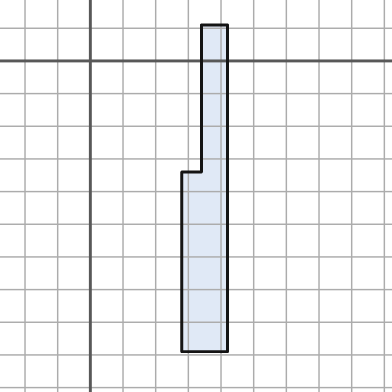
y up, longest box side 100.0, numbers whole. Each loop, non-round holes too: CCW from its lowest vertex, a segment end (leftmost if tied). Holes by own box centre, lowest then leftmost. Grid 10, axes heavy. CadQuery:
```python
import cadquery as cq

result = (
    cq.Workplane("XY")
    .moveTo(28.0, -89.0)
    .lineTo(42.0, -89.0)
    .lineTo(42.0, 11.0)
    .lineTo(34.0, 11.0)
    .lineTo(34.0, -34.0)
    .lineTo(28.0, -34.0)
    .close()
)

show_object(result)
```